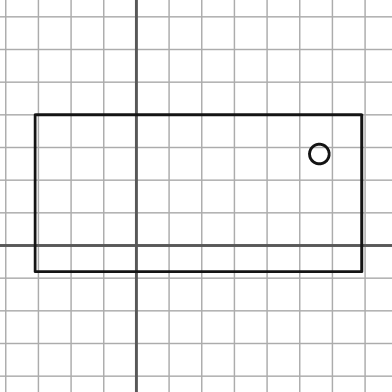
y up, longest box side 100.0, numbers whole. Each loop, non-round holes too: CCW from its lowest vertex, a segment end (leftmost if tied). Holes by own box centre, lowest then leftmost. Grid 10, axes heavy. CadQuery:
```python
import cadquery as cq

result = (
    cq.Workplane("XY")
    .moveTo(-31.0, -8.0)
    .lineTo(69.0, -8.0)
    .lineTo(69.0, 40.0)
    .lineTo(-31.0, 40.0)
    .close()
    .moveTo(56.0, 28.0)
    .circle(3.0)
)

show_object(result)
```